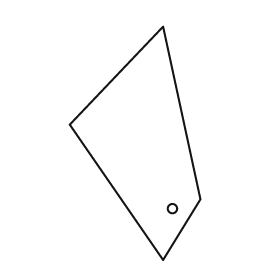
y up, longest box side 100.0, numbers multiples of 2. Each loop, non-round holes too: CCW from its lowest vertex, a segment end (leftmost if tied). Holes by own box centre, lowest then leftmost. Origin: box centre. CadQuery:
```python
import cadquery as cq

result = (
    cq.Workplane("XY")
    .moveTo(12.0, -50.0)
    .lineTo(28.0, -24.0)
    .lineTo(12.0, 50.0)
    .lineTo(-28.0, 8.0)
    .close()
    .moveTo(16.0, -28.0)
    .circle(2.0)
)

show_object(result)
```